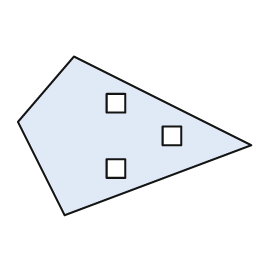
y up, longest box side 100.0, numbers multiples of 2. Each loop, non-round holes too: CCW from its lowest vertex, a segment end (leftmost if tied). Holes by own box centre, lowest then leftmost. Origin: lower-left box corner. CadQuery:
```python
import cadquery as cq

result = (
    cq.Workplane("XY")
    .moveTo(20.0, 0.0)
    .lineTo(100.0, 30.0)
    .lineTo(24.0, 68.0)
    .lineTo(0.0, 40.0)
    .close()
    .moveTo(38.0, 16.0)
    .lineTo(46.0, 16.0)
    .lineTo(46.0, 24.0)
    .lineTo(38.0, 24.0)
    .close()
    .moveTo(62.0, 30.0)
    .lineTo(70.0, 30.0)
    .lineTo(70.0, 38.0)
    .lineTo(62.0, 38.0)
    .close()
    .moveTo(38.0, 44.0)
    .lineTo(46.0, 44.0)
    .lineTo(46.0, 52.0)
    .lineTo(38.0, 52.0)
    .close()
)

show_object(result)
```